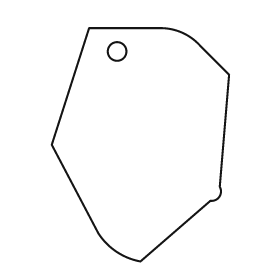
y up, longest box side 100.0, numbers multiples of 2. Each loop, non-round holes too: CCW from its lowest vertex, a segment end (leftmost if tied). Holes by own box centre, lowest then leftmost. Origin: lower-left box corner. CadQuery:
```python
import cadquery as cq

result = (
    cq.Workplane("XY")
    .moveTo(38.0, 0.0)
    .lineTo(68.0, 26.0)
    .threePointArc((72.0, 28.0), (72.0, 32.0))
    .lineTo(76.0, 80.0)
    .lineTo(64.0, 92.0)
    .threePointArc((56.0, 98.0), (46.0, 100.0))
    .lineTo(16.0, 100.0)
    .lineTo(0.0, 50.0)
    .lineTo(20.0, 12.0)
    .threePointArc((28.0, 4.0), (38.0, 0.0))
    .close()
    .moveTo(28.0, 90.0)
    .circle(4.0)
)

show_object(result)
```